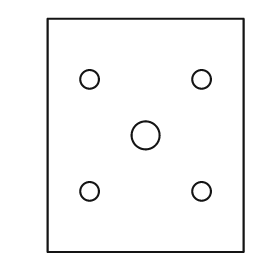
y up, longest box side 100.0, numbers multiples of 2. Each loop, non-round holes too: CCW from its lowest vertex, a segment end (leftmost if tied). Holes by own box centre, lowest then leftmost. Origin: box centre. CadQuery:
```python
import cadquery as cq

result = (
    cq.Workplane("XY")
    .moveTo(-42.0, -50.0)
    .lineTo(42.0, -50.0)
    .lineTo(42.0, 50.0)
    .lineTo(-42.0, 50.0)
    .close()
    .moveTo(-24.0, -24.0)
    .circle(4.0)
    .moveTo(24.0, -24.0)
    .circle(4.0)
    .moveTo(0.0, 0.0)
    .circle(6.0)
    .moveTo(-24.0, 24.0)
    .circle(4.0)
    .moveTo(24.0, 24.0)
    .circle(4.0)
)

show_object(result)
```